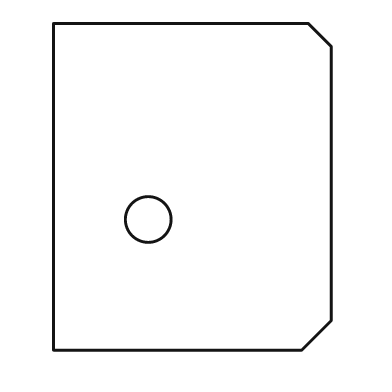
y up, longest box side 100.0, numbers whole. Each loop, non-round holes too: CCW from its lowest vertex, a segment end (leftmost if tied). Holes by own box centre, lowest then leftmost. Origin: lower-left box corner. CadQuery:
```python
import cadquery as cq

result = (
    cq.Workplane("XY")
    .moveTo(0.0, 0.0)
    .lineTo(76.0, 0.0)
    .lineTo(85.0, 9.0)
    .lineTo(85.0, 93.0)
    .lineTo(78.0, 100.0)
    .lineTo(0.0, 100.0)
    .close()
    .moveTo(29.0, 40.0)
    .circle(7.0)
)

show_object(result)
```